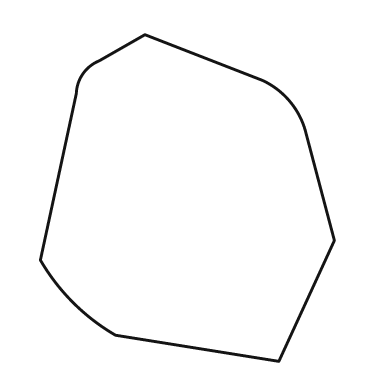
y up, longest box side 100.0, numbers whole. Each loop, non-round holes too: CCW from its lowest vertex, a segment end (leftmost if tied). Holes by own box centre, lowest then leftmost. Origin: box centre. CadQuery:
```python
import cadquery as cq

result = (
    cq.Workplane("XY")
    .moveTo(28.0, -50.0)
    .lineTo(45.0, -13.0)
    .lineTo(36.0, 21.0)
    .threePointArc((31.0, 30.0), (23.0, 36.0))
    .lineTo(-13.0, 50.0)
    .lineTo(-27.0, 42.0)
    .threePointArc((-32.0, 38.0), (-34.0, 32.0))
    .lineTo(-45.0, -19.0)
    .threePointArc((-35.0, -32.0), (-22.0, -42.0))
    .close()
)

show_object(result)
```